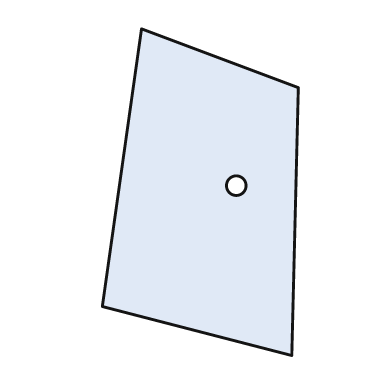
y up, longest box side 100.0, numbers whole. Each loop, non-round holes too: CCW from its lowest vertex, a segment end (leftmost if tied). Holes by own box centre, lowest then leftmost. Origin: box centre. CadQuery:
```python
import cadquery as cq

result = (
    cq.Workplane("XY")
    .moveTo(28.0, -50.0)
    .lineTo(30.0, 32.0)
    .lineTo(-18.0, 50.0)
    .lineTo(-30.0, -35.0)
    .close()
    .moveTo(11.0, 2.0)
    .circle(3.0)
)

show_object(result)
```